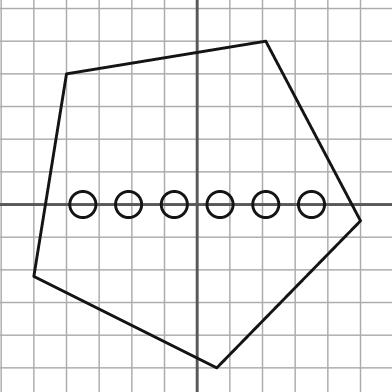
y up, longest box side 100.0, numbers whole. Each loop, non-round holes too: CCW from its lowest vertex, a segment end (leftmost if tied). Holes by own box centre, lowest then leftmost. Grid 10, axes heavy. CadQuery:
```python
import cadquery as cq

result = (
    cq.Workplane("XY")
    .moveTo(6.0, -50.0)
    .lineTo(50.0, -5.0)
    .lineTo(21.0, 50.0)
    .lineTo(-40.0, 40.0)
    .lineTo(-50.0, -22.0)
    .close()
    .moveTo(-35.0, 0.0)
    .circle(4.0)
    .moveTo(-21.0, 0.0)
    .circle(4.0)
    .moveTo(-7.0, 0.0)
    .circle(4.0)
    .moveTo(7.0, 0.0)
    .circle(4.0)
    .moveTo(21.0, 0.0)
    .circle(4.0)
    .moveTo(35.0, 0.0)
    .circle(4.0)
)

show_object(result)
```